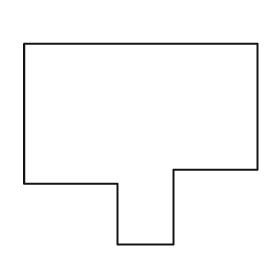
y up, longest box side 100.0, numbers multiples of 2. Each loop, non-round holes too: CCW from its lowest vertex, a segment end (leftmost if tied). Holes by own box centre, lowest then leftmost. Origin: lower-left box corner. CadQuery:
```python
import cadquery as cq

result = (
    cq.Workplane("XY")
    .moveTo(40.0, 0.0)
    .lineTo(64.0, 0.0)
    .lineTo(64.0, 32.0)
    .lineTo(100.0, 32.0)
    .lineTo(100.0, 86.0)
    .lineTo(0.0, 86.0)
    .lineTo(0.0, 26.0)
    .lineTo(40.0, 26.0)
    .close()
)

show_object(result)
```